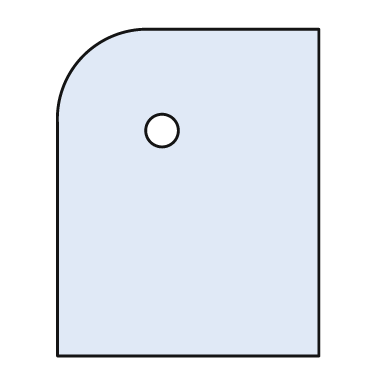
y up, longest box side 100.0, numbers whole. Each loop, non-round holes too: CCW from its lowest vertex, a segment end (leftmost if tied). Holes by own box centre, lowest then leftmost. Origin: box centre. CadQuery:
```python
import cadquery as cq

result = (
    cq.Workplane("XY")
    .moveTo(-40.0, -50.0)
    .lineTo(40.0, -50.0)
    .lineTo(40.0, 50.0)
    .lineTo(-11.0, 50.0)
    .threePointArc((-32.0, 42.0), (-40.0, 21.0))
    .close()
    .moveTo(-8.0, 19.0)
    .circle(5.0)
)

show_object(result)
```